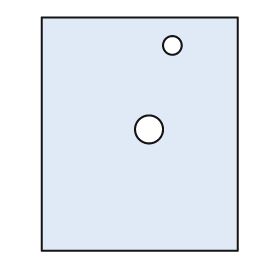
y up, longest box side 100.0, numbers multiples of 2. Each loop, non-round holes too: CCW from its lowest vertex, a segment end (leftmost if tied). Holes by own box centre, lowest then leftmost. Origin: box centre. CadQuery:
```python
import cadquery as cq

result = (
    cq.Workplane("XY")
    .moveTo(-42.0, -50.0)
    .lineTo(42.0, -50.0)
    .lineTo(42.0, 50.0)
    .lineTo(-42.0, 50.0)
    .close()
    .moveTo(4.0, 2.0)
    .circle(6.0)
    .moveTo(14.0, 38.0)
    .circle(4.0)
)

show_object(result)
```